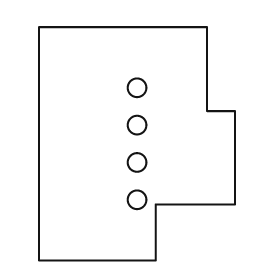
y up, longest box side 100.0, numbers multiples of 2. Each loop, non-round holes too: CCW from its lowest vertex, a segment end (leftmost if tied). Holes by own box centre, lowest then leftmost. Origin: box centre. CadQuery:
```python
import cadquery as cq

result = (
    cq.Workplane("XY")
    .moveTo(-42.0, -50.0)
    .lineTo(8.0, -50.0)
    .lineTo(8.0, -26.0)
    .lineTo(42.0, -26.0)
    .lineTo(42.0, 14.0)
    .lineTo(30.0, 14.0)
    .lineTo(30.0, 50.0)
    .lineTo(-42.0, 50.0)
    .close()
    .moveTo(0.0, -24.0)
    .circle(4.0)
    .moveTo(0.0, -8.0)
    .circle(4.0)
    .moveTo(0.0, 8.0)
    .circle(4.0)
    .moveTo(0.0, 24.0)
    .circle(4.0)
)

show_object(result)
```